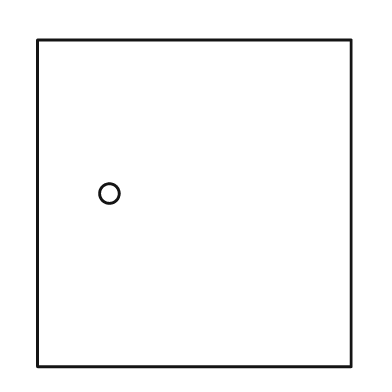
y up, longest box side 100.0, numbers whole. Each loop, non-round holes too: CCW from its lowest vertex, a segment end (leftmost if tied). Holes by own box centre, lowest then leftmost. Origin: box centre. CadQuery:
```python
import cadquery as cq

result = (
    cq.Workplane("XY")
    .moveTo(-48.0, -50.0)
    .lineTo(48.0, -50.0)
    .lineTo(48.0, 50.0)
    .lineTo(-48.0, 50.0)
    .close()
    .moveTo(-26.0, 3.0)
    .circle(3.0)
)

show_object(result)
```